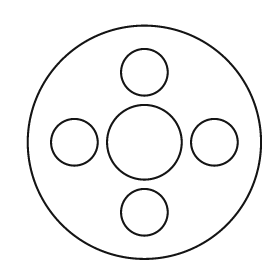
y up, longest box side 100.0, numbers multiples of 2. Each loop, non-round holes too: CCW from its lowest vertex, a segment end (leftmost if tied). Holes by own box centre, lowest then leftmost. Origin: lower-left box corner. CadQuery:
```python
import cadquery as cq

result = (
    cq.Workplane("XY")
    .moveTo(50.0, 50.0)
    .circle(50.0)
    .moveTo(50.0, 20.0)
    .circle(10.0)
    .moveTo(20.0, 50.0)
    .circle(10.0)
    .moveTo(50.0, 50.0)
    .circle(16.0)
    .moveTo(80.0, 50.0)
    .circle(10.0)
    .moveTo(50.0, 80.0)
    .circle(10.0)
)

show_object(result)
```